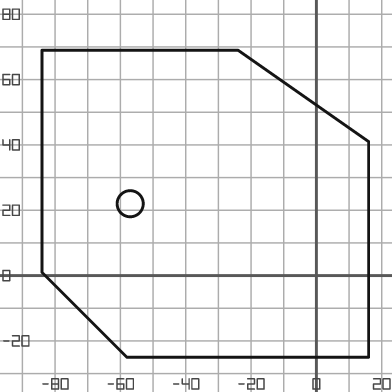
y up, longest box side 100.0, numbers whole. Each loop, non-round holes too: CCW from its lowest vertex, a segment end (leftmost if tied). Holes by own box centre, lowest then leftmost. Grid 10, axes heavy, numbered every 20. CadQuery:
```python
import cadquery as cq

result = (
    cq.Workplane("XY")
    .moveTo(-58.0, -25.0)
    .lineTo(16.0, -25.0)
    .lineTo(16.0, 41.0)
    .lineTo(-24.0, 69.0)
    .lineTo(-84.0, 69.0)
    .lineTo(-84.0, 1.0)
    .close()
    .moveTo(-57.0, 22.0)
    .circle(4.0)
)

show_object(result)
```